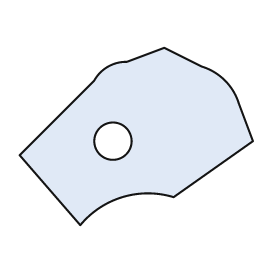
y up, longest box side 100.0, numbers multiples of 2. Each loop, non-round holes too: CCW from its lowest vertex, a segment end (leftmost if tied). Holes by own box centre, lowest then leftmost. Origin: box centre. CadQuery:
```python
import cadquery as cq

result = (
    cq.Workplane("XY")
    .moveTo(-24.0, -38.0)
    .threePointArc((-6.0, -26.0), (16.0, -26.0))
    .lineTo(50.0, -2.0)
    .lineTo(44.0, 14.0)
    .threePointArc((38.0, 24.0), (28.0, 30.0))
    .lineTo(12.0, 38.0)
    .lineTo(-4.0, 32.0)
    .threePointArc((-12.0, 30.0), (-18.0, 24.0))
    .lineTo(-50.0, -8.0)
    .close()
    .moveTo(-10.0, -2.0)
    .circle(8.0)
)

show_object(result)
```